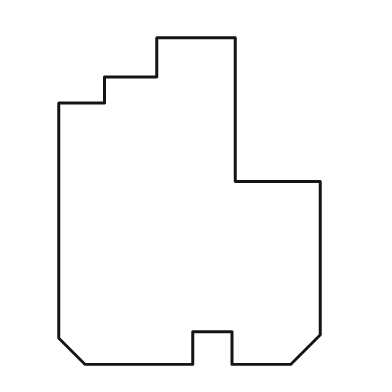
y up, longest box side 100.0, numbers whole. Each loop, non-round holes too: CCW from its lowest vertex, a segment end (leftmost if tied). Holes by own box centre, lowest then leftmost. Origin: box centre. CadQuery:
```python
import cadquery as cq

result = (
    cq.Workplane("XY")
    .moveTo(-32.0, -50.0)
    .lineTo(1.0, -50.0)
    .lineTo(1.0, -40.0)
    .lineTo(13.0, -40.0)
    .lineTo(13.0, -50.0)
    .lineTo(31.0, -50.0)
    .lineTo(40.0, -41.0)
    .lineTo(40.0, 6.0)
    .lineTo(14.0, 6.0)
    .lineTo(14.0, 50.0)
    .lineTo(-10.0, 50.0)
    .lineTo(-10.0, 38.0)
    .lineTo(-26.0, 38.0)
    .lineTo(-26.0, 30.0)
    .lineTo(-40.0, 30.0)
    .lineTo(-40.0, -42.0)
    .close()
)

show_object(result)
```